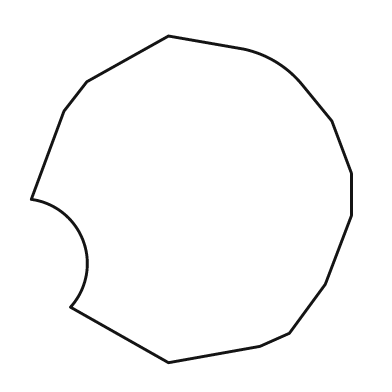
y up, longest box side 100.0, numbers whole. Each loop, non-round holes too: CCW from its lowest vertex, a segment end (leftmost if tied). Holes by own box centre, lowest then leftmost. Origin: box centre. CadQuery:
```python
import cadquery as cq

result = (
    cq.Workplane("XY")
    .moveTo(-7.0, -50.0)
    .lineTo(21.0, -45.0)
    .lineTo(30.0, -41.0)
    .lineTo(41.0, -26.0)
    .lineTo(49.0, -5.0)
    .lineTo(49.0, 8.0)
    .lineTo(43.0, 24.0)
    .lineTo(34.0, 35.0)
    .threePointArc((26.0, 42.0), (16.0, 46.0))
    .lineTo(-7.0, 50.0)
    .lineTo(-32.0, 36.0)
    .lineTo(-39.0, 27.0)
    .lineTo(-49.0, 0.0)
    .threePointArc((-33.0, -13.0), (-37.0, -33.0))
    .close()
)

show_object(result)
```